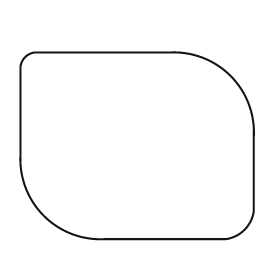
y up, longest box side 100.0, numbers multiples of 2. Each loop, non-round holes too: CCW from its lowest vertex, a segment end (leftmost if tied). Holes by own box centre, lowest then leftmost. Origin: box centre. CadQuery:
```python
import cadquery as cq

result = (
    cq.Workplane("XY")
    .moveTo(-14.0, -40.0)
    .lineTo(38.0, -40.0)
    .threePointArc((46.0, -36.0), (50.0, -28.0))
    .lineTo(50.0, 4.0)
    .threePointArc((40.0, 30.0), (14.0, 40.0))
    .lineTo(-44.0, 40.0)
    .threePointArc((-48.0, 38.0), (-50.0, 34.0))
    .lineTo(-50.0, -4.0)
    .threePointArc((-40.0, -30.0), (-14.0, -40.0))
    .close()
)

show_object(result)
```